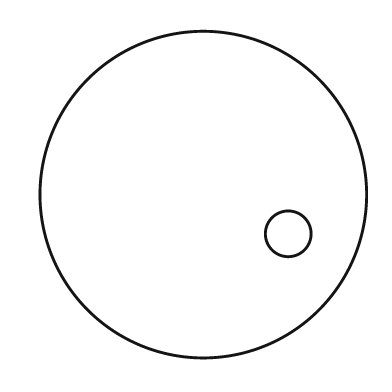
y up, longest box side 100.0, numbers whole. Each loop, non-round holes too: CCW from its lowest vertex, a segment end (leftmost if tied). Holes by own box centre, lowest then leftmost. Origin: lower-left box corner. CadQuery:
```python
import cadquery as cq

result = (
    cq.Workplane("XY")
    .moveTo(50.0, 50.0)
    .circle(50.0)
    .moveTo(76.0, 38.0)
    .circle(7.0)
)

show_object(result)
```